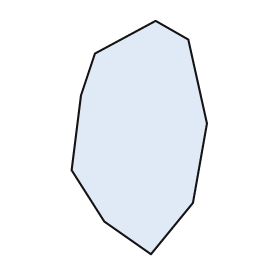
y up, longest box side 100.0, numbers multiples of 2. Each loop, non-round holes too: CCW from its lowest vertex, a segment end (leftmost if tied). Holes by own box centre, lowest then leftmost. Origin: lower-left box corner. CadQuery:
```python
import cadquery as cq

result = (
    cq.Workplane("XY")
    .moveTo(34.0, 0.0)
    .lineTo(52.0, 22.0)
    .lineTo(58.0, 56.0)
    .lineTo(50.0, 92.0)
    .lineTo(36.0, 100.0)
    .lineTo(10.0, 86.0)
    .lineTo(4.0, 68.0)
    .lineTo(0.0, 36.0)
    .lineTo(14.0, 14.0)
    .close()
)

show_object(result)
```